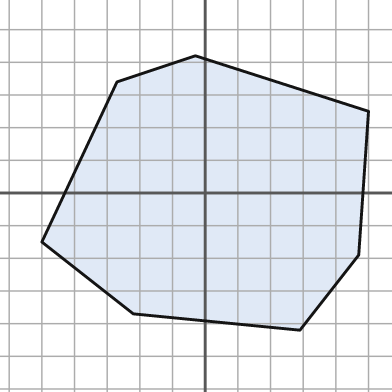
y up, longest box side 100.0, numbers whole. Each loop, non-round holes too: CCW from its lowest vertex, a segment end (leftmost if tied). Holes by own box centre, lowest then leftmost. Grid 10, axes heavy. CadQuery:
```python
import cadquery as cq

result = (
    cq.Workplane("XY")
    .moveTo(29.0, -42.0)
    .lineTo(47.0, -19.0)
    .lineTo(50.0, 25.0)
    .lineTo(-3.0, 42.0)
    .lineTo(-27.0, 34.0)
    .lineTo(-50.0, -15.0)
    .lineTo(-22.0, -37.0)
    .close()
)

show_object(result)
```